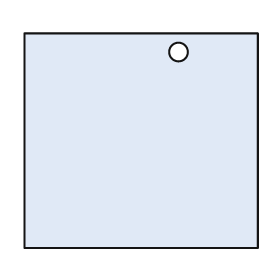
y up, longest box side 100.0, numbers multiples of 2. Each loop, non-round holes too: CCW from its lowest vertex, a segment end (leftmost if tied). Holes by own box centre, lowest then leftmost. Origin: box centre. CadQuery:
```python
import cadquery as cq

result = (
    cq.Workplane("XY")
    .moveTo(-50.0, -46.0)
    .lineTo(50.0, -46.0)
    .lineTo(50.0, 46.0)
    .lineTo(-50.0, 46.0)
    .close()
    .moveTo(16.0, 38.0)
    .circle(4.0)
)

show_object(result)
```